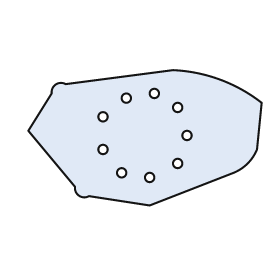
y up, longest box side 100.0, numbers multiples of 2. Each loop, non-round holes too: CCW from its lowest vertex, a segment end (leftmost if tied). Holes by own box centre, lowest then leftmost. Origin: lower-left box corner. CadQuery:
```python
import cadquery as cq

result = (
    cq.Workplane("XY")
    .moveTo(52.0, 0.0)
    .lineTo(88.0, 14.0)
    .threePointArc((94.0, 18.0), (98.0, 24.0))
    .lineTo(100.0, 44.0)
    .threePointArc((82.0, 54.0), (62.0, 58.0))
    .lineTo(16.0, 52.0)
    .threePointArc((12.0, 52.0), (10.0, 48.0))
    .lineTo(0.0, 32.0)
    .lineTo(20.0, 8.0)
    .threePointArc((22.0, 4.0), (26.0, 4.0))
    .close()
    .moveTo(52.0, 12.0)
    .circle(2.0)
    .moveTo(40.0, 14.0)
    .circle(2.0)
    .moveTo(64.0, 18.0)
    .circle(2.0)
    .moveTo(32.0, 24.0)
    .circle(2.0)
    .moveTo(68.0, 30.0)
    .circle(2.0)
    .moveTo(32.0, 38.0)
    .circle(2.0)
    .moveTo(64.0, 42.0)
    .circle(2.0)
    .moveTo(42.0, 46.0)
    .circle(2.0)
    .moveTo(54.0, 48.0)
    .circle(2.0)
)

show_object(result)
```